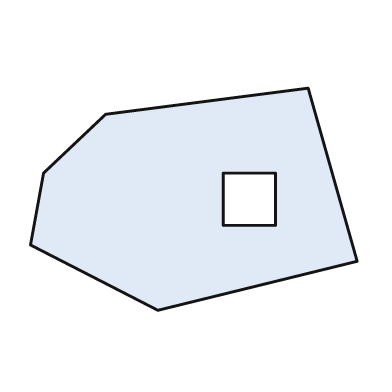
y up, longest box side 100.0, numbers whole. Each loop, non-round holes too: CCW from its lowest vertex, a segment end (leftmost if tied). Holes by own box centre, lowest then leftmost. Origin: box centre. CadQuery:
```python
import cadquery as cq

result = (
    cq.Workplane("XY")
    .moveTo(-11.0, -34.0)
    .lineTo(50.0, -19.0)
    .lineTo(35.0, 34.0)
    .lineTo(-27.0, 26.0)
    .lineTo(-46.0, 8.0)
    .lineTo(-50.0, -14.0)
    .close()
    .moveTo(9.0, -8.0)
    .lineTo(25.0, -8.0)
    .lineTo(25.0, 8.0)
    .lineTo(9.0, 8.0)
    .close()
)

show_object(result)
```